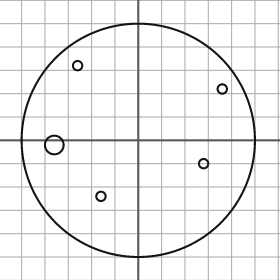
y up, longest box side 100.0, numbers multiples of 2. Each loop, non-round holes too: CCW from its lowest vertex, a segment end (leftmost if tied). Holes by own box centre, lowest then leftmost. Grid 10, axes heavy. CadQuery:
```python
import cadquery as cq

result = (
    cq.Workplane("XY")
    .moveTo(0.0, 0.0)
    .circle(50.0)
    .moveTo(-16.0, -24.0)
    .circle(2.0)
    .moveTo(28.0, -10.0)
    .circle(2.0)
    .moveTo(-36.0, -2.0)
    .circle(4.0)
    .moveTo(36.0, 22.0)
    .circle(2.0)
    .moveTo(-26.0, 32.0)
    .circle(2.0)
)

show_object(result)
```